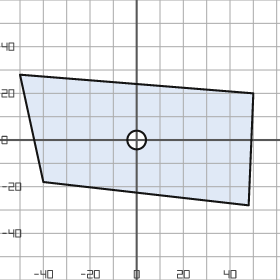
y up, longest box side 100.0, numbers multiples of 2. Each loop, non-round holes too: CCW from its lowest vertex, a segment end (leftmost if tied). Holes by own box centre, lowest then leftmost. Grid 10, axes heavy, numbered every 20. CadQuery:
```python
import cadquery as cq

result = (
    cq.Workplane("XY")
    .moveTo(48.0, -28.0)
    .lineTo(50.0, 20.0)
    .lineTo(-50.0, 28.0)
    .lineTo(-40.0, -18.0)
    .close()
    .moveTo(0.0, 0.0)
    .circle(4.0)
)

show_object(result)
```